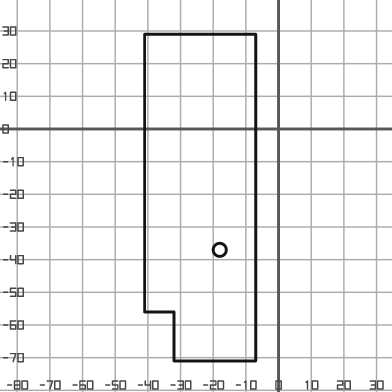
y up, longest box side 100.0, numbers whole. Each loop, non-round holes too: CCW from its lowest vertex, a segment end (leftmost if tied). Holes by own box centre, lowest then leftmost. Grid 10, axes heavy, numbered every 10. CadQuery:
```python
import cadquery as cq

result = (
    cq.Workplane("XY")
    .moveTo(-32.0, -71.0)
    .lineTo(-7.0, -71.0)
    .lineTo(-7.0, 29.0)
    .lineTo(-41.0, 29.0)
    .lineTo(-41.0, -56.0)
    .lineTo(-32.0, -56.0)
    .close()
    .moveTo(-18.0, -37.0)
    .circle(2.0)
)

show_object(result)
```